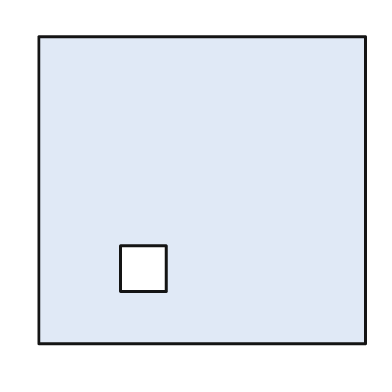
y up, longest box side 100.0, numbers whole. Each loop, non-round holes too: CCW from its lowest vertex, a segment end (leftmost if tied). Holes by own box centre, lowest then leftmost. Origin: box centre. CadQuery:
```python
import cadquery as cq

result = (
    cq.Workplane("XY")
    .moveTo(-50.0, -47.0)
    .lineTo(50.0, -47.0)
    .lineTo(50.0, 47.0)
    .lineTo(-50.0, 47.0)
    .close()
    .moveTo(-25.0, -31.0)
    .lineTo(-11.0, -31.0)
    .lineTo(-11.0, -17.0)
    .lineTo(-25.0, -17.0)
    .close()
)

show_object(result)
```